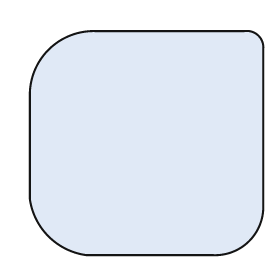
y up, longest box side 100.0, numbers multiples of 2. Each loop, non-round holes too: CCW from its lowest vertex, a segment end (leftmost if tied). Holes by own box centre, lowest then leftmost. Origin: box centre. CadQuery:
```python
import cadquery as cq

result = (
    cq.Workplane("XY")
    .moveTo(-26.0, -48.0)
    .lineTo(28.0, -48.0)
    .threePointArc((44.0, -42.0), (50.0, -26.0))
    .lineTo(50.0, 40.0)
    .threePointArc((48.0, 46.0), (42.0, 48.0))
    .lineTo(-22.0, 48.0)
    .threePointArc((-42.0, 40.0), (-50.0, 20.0))
    .lineTo(-50.0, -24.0)
    .threePointArc((-42.0, -40.0), (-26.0, -48.0))
    .close()
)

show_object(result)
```